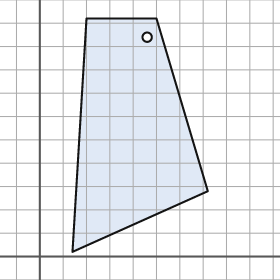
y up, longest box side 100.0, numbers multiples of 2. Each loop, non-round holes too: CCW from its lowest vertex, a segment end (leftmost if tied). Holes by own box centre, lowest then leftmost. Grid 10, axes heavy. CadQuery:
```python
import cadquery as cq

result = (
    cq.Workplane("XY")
    .moveTo(14.0, 2.0)
    .lineTo(72.0, 28.0)
    .lineTo(50.0, 102.0)
    .lineTo(20.0, 102.0)
    .close()
    .moveTo(46.0, 94.0)
    .circle(2.0)
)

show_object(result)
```